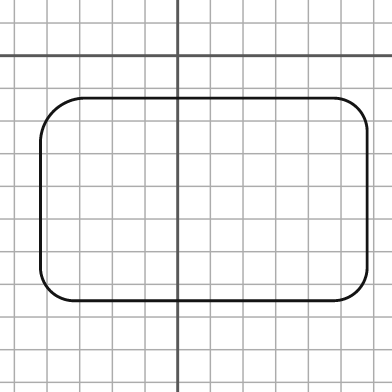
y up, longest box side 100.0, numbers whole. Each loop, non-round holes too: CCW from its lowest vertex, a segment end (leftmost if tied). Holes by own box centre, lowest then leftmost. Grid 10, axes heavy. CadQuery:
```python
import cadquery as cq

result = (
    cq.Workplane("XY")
    .moveTo(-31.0, -75.0)
    .lineTo(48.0, -75.0)
    .threePointArc((55.0, -72.0), (58.0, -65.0))
    .lineTo(58.0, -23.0)
    .threePointArc((55.0, -16.0), (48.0, -13.0))
    .lineTo(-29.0, -13.0)
    .threePointArc((-38.0, -17.0), (-42.0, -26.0))
    .lineTo(-42.0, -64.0)
    .threePointArc((-39.0, -72.0), (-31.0, -75.0))
    .close()
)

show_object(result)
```